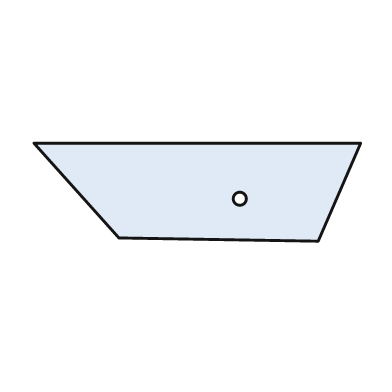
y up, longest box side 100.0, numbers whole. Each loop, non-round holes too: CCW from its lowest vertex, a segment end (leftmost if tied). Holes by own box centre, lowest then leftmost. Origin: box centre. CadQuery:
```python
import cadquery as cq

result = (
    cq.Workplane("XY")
    .moveTo(37.0, -15.0)
    .lineTo(50.0, 15.0)
    .lineTo(-50.0, 15.0)
    .lineTo(-24.0, -14.0)
    .close()
    .moveTo(13.0, -2.0)
    .circle(2.0)
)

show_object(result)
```